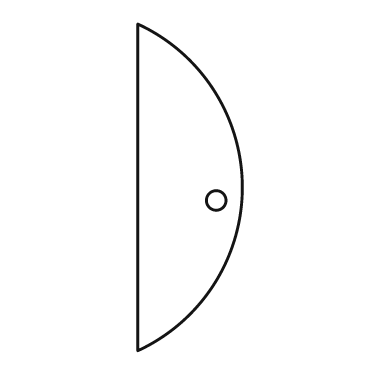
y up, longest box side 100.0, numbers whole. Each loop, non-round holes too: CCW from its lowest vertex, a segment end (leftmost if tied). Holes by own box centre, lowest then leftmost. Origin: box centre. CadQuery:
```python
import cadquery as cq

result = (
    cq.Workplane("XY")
    .moveTo(-16.0, -50.0)
    .threePointArc((16.0, 0.0), (-16.0, 50.0))
    .close()
    .moveTo(8.0, -4.0)
    .circle(3.0)
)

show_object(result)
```